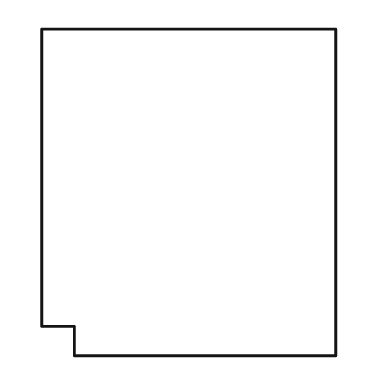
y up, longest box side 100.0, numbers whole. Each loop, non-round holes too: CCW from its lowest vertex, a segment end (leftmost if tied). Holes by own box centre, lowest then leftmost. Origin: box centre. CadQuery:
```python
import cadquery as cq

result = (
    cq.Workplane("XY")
    .moveTo(-35.0, -50.0)
    .lineTo(45.0, -50.0)
    .lineTo(45.0, 50.0)
    .lineTo(-45.0, 50.0)
    .lineTo(-45.0, -41.0)
    .lineTo(-35.0, -41.0)
    .close()
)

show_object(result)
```